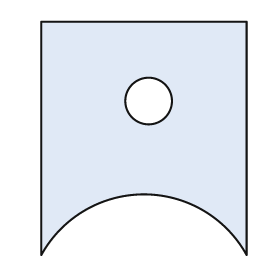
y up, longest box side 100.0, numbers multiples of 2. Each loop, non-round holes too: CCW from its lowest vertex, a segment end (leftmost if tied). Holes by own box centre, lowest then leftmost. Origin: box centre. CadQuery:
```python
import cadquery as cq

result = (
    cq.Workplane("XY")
    .moveTo(-44.0, -50.0)
    .threePointArc((0.0, -24.0), (44.0, -50.0))
    .lineTo(44.0, 50.0)
    .lineTo(-44.0, 50.0)
    .close()
    .moveTo(2.0, 16.0)
    .circle(10.0)
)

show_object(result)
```